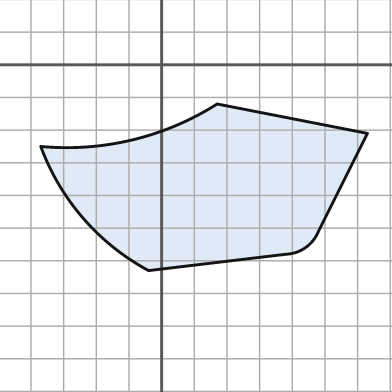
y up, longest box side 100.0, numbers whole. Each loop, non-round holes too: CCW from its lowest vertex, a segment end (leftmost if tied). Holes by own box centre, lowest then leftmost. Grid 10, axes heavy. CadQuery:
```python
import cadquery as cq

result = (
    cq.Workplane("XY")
    .moveTo(-4.0, -63.0)
    .lineTo(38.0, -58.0)
    .threePointArc((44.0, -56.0), (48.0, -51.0))
    .lineTo(63.0, -21.0)
    .lineTo(17.0, -12.0)
    .threePointArc((-9.0, -23.0), (-37.0, -25.0))
    .threePointArc((-24.0, -47.0), (-4.0, -63.0))
    .close()
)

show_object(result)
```